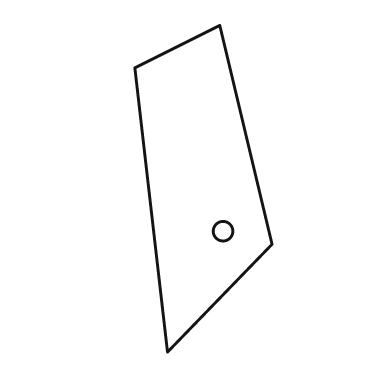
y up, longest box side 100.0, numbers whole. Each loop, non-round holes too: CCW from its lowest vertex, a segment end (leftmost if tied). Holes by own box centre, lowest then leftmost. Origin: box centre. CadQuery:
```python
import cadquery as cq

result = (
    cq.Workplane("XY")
    .moveTo(-11.0, -50.0)
    .lineTo(21.0, -17.0)
    .lineTo(5.0, 50.0)
    .lineTo(-21.0, 37.0)
    .close()
    .moveTo(6.0, -13.0)
    .circle(3.0)
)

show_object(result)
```